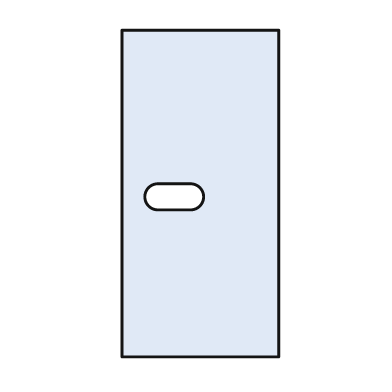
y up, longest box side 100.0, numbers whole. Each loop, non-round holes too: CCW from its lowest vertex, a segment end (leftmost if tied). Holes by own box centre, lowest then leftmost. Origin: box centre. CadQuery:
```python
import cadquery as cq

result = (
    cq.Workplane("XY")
    .moveTo(-24.0, -50.0)
    .lineTo(24.0, -50.0)
    .lineTo(24.0, 50.0)
    .lineTo(-24.0, 50.0)
    .close()
    .moveTo(-13.0, -5.0)
    .lineTo(-3.0, -5.0)
    .threePointArc((1.0, -1.0), (-3.0, 3.0))
    .lineTo(-13.0, 3.0)
    .threePointArc((-17.0, -1.0), (-13.0, -5.0))
    .close()
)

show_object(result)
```